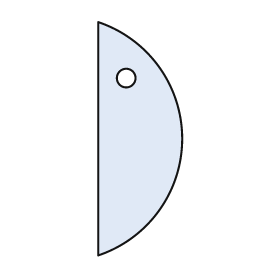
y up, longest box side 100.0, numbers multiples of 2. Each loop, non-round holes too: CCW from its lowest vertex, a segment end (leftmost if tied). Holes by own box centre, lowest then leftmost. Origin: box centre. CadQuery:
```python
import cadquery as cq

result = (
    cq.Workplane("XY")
    .moveTo(-18.0, -50.0)
    .threePointArc((18.0, 0.0), (-18.0, 50.0))
    .close()
    .moveTo(-6.0, 26.0)
    .circle(4.0)
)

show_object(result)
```